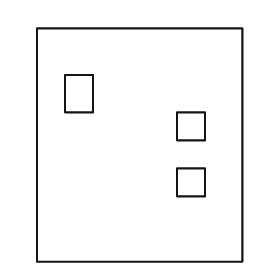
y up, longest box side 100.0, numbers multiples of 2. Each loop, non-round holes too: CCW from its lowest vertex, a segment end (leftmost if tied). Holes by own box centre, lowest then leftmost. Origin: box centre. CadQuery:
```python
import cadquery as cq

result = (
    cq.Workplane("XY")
    .moveTo(-44.0, -50.0)
    .lineTo(44.0, -50.0)
    .lineTo(44.0, 50.0)
    .lineTo(-44.0, 50.0)
    .close()
    .moveTo(16.0, -22.0)
    .lineTo(28.0, -22.0)
    .lineTo(28.0, -10.0)
    .lineTo(16.0, -10.0)
    .close()
    .moveTo(16.0, 2.0)
    .lineTo(28.0, 2.0)
    .lineTo(28.0, 14.0)
    .lineTo(16.0, 14.0)
    .close()
    .moveTo(-32.0, 14.0)
    .lineTo(-20.0, 14.0)
    .lineTo(-20.0, 30.0)
    .lineTo(-32.0, 30.0)
    .close()
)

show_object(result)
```